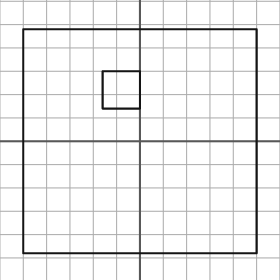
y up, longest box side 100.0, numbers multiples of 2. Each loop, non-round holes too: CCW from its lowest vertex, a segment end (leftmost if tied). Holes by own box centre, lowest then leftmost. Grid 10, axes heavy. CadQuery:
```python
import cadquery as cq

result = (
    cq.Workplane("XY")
    .moveTo(-50.0, -48.0)
    .lineTo(50.0, -48.0)
    .lineTo(50.0, 48.0)
    .lineTo(-50.0, 48.0)
    .close()
    .moveTo(-16.0, 14.0)
    .lineTo(0.0, 14.0)
    .lineTo(0.0, 30.0)
    .lineTo(-16.0, 30.0)
    .close()
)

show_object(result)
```